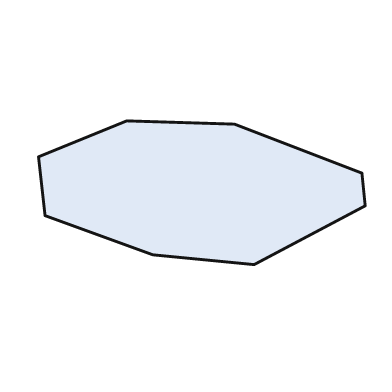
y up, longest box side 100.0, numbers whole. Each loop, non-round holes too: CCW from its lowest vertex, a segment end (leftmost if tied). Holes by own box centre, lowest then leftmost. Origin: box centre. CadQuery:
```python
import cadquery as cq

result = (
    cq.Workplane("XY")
    .moveTo(16.0, -22.0)
    .lineTo(50.0, -4.0)
    .lineTo(49.0, 6.0)
    .lineTo(10.0, 21.0)
    .lineTo(-23.0, 22.0)
    .lineTo(-50.0, 11.0)
    .lineTo(-48.0, -7.0)
    .lineTo(-15.0, -19.0)
    .close()
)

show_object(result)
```